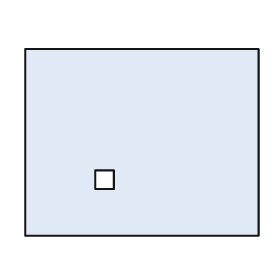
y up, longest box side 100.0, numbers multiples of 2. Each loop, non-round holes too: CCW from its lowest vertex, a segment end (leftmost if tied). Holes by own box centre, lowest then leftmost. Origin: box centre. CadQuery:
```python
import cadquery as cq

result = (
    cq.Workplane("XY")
    .moveTo(-50.0, -40.0)
    .lineTo(50.0, -40.0)
    .lineTo(50.0, 40.0)
    .lineTo(-50.0, 40.0)
    .close()
    .moveTo(-20.0, -20.0)
    .lineTo(-12.0, -20.0)
    .lineTo(-12.0, -12.0)
    .lineTo(-20.0, -12.0)
    .close()
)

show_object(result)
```